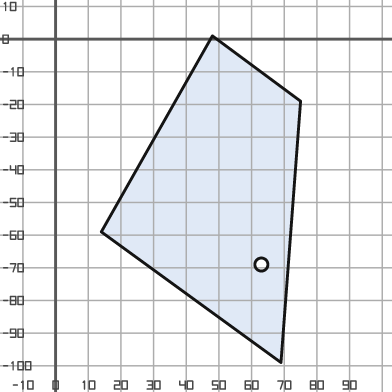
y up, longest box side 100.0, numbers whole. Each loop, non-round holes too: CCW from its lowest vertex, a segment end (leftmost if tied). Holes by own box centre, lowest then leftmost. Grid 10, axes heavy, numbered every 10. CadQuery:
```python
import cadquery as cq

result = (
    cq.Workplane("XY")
    .moveTo(69.0, -99.0)
    .lineTo(75.0, -19.0)
    .lineTo(48.0, 1.0)
    .lineTo(14.0, -59.0)
    .close()
    .moveTo(63.0, -69.0)
    .circle(2.0)
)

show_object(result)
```